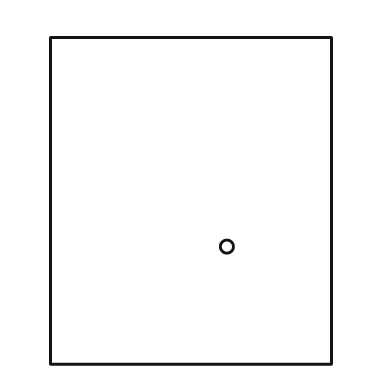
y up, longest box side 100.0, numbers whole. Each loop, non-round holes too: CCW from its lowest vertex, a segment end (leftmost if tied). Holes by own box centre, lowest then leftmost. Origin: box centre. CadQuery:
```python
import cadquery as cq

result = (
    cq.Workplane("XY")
    .moveTo(-43.0, -50.0)
    .lineTo(43.0, -50.0)
    .lineTo(43.0, 50.0)
    .lineTo(-43.0, 50.0)
    .close()
    .moveTo(11.0, -14.0)
    .circle(2.0)
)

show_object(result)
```